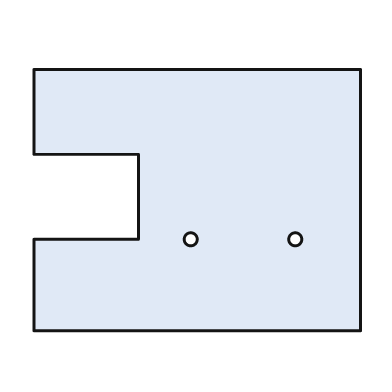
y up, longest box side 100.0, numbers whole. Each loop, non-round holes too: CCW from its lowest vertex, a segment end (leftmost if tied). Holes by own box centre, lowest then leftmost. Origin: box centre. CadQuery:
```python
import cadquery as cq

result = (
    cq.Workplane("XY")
    .moveTo(-50.0, -40.0)
    .lineTo(50.0, -40.0)
    .lineTo(50.0, 40.0)
    .lineTo(-50.0, 40.0)
    .lineTo(-50.0, 14.0)
    .lineTo(-18.0, 14.0)
    .lineTo(-18.0, -12.0)
    .lineTo(-50.0, -12.0)
    .close()
    .moveTo(-2.0, -12.0)
    .circle(2.0)
    .moveTo(30.0, -12.0)
    .circle(2.0)
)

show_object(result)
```